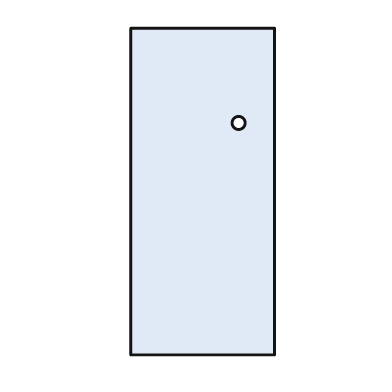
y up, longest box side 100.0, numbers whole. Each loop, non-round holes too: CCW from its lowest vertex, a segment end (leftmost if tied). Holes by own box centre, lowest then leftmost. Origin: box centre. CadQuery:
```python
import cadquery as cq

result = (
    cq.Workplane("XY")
    .moveTo(-22.0, -50.0)
    .lineTo(22.0, -50.0)
    .lineTo(22.0, 50.0)
    .lineTo(-22.0, 50.0)
    .close()
    .moveTo(11.0, 21.0)
    .circle(2.0)
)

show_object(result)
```